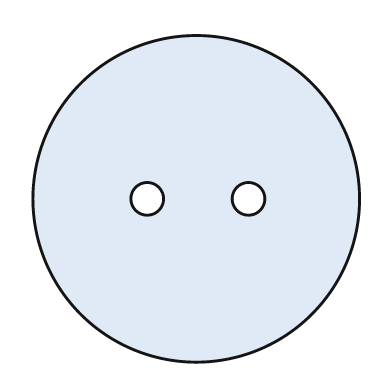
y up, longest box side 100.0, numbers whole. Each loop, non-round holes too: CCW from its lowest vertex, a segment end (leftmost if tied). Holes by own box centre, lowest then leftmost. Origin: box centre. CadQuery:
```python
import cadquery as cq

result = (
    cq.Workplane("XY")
    .moveTo(0.0, 0.0)
    .circle(50.0)
    .moveTo(-15.0, 0.0)
    .circle(5.0)
    .moveTo(16.0, 0.0)
    .circle(5.0)
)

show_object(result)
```